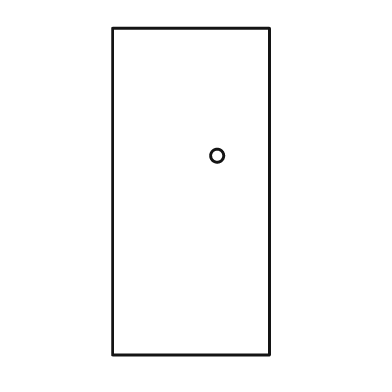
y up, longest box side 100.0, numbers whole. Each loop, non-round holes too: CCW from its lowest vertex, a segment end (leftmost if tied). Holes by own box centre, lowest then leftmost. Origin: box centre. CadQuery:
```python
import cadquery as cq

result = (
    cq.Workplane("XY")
    .moveTo(-24.0, -50.0)
    .lineTo(24.0, -50.0)
    .lineTo(24.0, 50.0)
    .lineTo(-24.0, 50.0)
    .close()
    .moveTo(8.0, 11.0)
    .circle(2.0)
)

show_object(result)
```